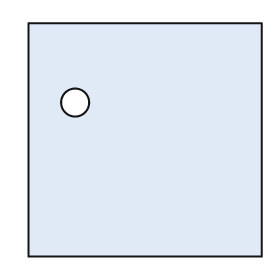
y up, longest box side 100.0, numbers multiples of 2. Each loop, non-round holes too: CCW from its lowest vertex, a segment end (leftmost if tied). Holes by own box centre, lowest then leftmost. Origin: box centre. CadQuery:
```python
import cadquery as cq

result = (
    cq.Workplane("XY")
    .moveTo(-50.0, -50.0)
    .lineTo(50.0, -50.0)
    .lineTo(50.0, 50.0)
    .lineTo(-50.0, 50.0)
    .close()
    .moveTo(-30.0, 16.0)
    .circle(6.0)
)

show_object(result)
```